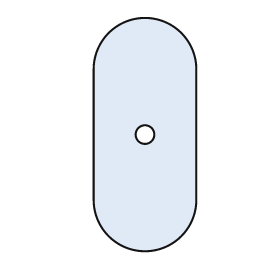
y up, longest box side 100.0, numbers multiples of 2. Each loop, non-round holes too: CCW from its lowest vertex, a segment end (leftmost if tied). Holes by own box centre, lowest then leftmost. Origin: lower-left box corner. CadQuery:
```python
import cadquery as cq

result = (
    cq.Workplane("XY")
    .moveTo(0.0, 22.0)
    .threePointArc((22.0, 0.0), (44.0, 22.0))
    .lineTo(44.0, 78.0)
    .threePointArc((22.0, 100.0), (0.0, 78.0))
    .close()
    .moveTo(22.0, 50.0)
    .circle(4.0)
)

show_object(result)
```